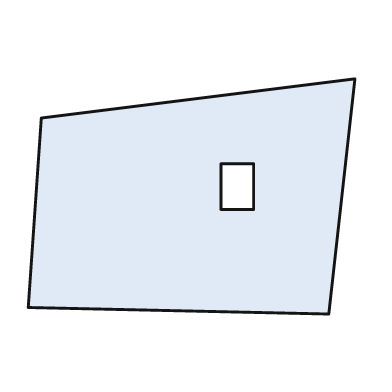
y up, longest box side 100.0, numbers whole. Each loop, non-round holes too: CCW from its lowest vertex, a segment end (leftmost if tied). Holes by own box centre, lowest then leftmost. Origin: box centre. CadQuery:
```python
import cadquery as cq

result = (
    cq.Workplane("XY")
    .moveTo(42.0, -36.0)
    .lineTo(50.0, 36.0)
    .lineTo(-46.0, 24.0)
    .lineTo(-50.0, -34.0)
    .close()
    .moveTo(9.0, -4.0)
    .lineTo(19.0, -4.0)
    .lineTo(19.0, 10.0)
    .lineTo(9.0, 10.0)
    .close()
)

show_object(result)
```